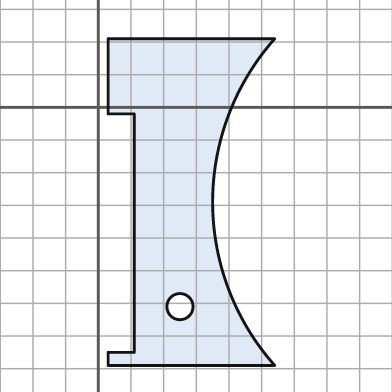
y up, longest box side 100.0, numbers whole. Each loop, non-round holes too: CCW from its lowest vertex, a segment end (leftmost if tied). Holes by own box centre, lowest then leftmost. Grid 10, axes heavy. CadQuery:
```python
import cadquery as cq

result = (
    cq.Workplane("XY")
    .moveTo(3.0, -79.0)
    .lineTo(54.0, -79.0)
    .threePointArc((35.0, -29.0), (54.0, 21.0))
    .lineTo(3.0, 21.0)
    .lineTo(3.0, -2.0)
    .lineTo(11.0, -2.0)
    .lineTo(11.0, -75.0)
    .lineTo(3.0, -75.0)
    .close()
    .moveTo(25.0, -61.0)
    .circle(4.0)
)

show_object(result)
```